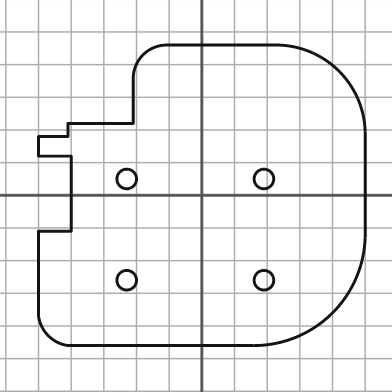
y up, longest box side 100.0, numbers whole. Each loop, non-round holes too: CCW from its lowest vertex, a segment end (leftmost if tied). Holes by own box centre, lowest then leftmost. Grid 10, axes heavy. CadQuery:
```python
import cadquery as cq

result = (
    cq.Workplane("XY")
    .moveTo(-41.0, -46.0)
    .lineTo(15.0, -46.0)
    .threePointArc((40.0, -36.0), (50.0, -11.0))
    .lineTo(50.0, 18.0)
    .threePointArc((42.0, 38.0), (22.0, 46.0))
    .lineTo(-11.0, 46.0)
    .threePointArc((-18.0, 43.0), (-21.0, 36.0))
    .lineTo(-21.0, 22.0)
    .lineTo(-41.0, 22.0)
    .lineTo(-41.0, 18.0)
    .lineTo(-50.0, 18.0)
    .lineTo(-50.0, 12.0)
    .lineTo(-40.0, 12.0)
    .lineTo(-40.0, -11.0)
    .lineTo(-50.0, -11.0)
    .lineTo(-50.0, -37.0)
    .threePointArc((-47.0, -43.0), (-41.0, -46.0))
    .close()
    .moveTo(-23.0, -26.0)
    .circle(3.0)
    .moveTo(19.0, -26.0)
    .circle(3.0)
    .moveTo(-23.0, 5.0)
    .circle(3.0)
    .moveTo(19.0, 5.0)
    .circle(3.0)
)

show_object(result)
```